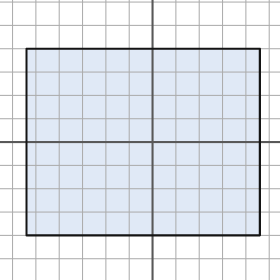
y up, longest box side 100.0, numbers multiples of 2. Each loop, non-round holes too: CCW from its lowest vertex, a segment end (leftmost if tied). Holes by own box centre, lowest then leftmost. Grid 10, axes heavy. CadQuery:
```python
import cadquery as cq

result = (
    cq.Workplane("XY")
    .moveTo(-54.0, -40.0)
    .lineTo(46.0, -40.0)
    .lineTo(46.0, 40.0)
    .lineTo(-54.0, 40.0)
    .close()
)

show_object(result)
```